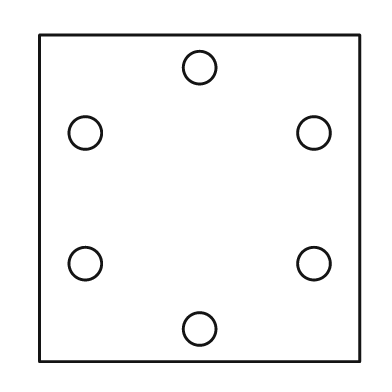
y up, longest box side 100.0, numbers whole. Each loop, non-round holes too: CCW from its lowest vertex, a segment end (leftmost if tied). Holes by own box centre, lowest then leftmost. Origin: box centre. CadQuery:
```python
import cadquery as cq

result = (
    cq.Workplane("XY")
    .moveTo(-49.0, -50.0)
    .lineTo(49.0, -50.0)
    .lineTo(49.0, 50.0)
    .lineTo(-49.0, 50.0)
    .close()
    .moveTo(0.0, -40.0)
    .circle(5.0)
    .moveTo(-35.0, -20.0)
    .circle(5.0)
    .moveTo(35.0, -20.0)
    .circle(5.0)
    .moveTo(-35.0, 20.0)
    .circle(5.0)
    .moveTo(35.0, 20.0)
    .circle(5.0)
    .moveTo(0.0, 40.0)
    .circle(5.0)
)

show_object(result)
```